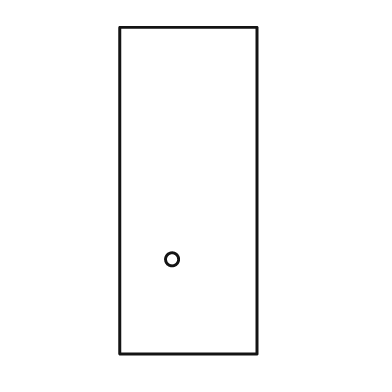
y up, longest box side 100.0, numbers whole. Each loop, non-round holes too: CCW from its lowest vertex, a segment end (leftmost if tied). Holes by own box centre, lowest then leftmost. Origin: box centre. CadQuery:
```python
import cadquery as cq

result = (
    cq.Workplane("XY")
    .moveTo(-21.0, -50.0)
    .lineTo(21.0, -50.0)
    .lineTo(21.0, 50.0)
    .lineTo(-21.0, 50.0)
    .close()
    .moveTo(-5.0, -21.0)
    .circle(2.0)
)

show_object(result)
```